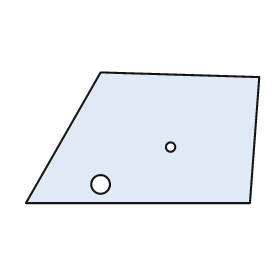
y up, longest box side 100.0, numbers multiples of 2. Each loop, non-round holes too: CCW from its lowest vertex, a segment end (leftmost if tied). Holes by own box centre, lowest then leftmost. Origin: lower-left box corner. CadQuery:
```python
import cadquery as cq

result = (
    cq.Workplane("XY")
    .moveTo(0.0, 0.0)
    .lineTo(96.0, 0.0)
    .lineTo(100.0, 54.0)
    .lineTo(32.0, 56.0)
    .close()
    .moveTo(32.0, 8.0)
    .circle(4.0)
    .moveTo(62.0, 24.0)
    .circle(2.0)
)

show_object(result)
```